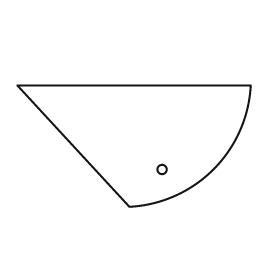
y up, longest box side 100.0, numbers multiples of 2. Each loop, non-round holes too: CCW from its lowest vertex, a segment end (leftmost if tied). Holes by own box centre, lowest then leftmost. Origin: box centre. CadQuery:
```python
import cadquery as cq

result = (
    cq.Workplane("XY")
    .moveTo(-2.0, -26.0)
    .threePointArc((34.0, -10.0), (50.0, 26.0))
    .lineTo(-50.0, 26.0)
    .close()
    .moveTo(12.0, -10.0)
    .circle(2.0)
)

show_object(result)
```